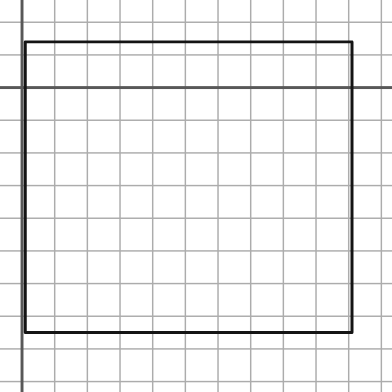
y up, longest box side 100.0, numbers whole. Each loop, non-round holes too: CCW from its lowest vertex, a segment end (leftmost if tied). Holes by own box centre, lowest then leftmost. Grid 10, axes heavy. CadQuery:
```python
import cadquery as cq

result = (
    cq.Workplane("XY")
    .moveTo(1.0, -75.0)
    .lineTo(101.0, -75.0)
    .lineTo(101.0, 14.0)
    .lineTo(1.0, 14.0)
    .close()
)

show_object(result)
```